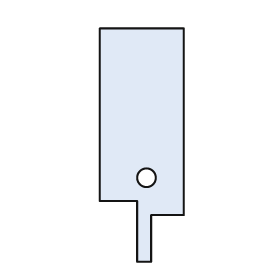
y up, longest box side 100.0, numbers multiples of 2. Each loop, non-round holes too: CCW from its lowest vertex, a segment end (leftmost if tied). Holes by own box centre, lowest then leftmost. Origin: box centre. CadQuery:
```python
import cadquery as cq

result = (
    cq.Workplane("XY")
    .moveTo(-2.0, -50.0)
    .lineTo(4.0, -50.0)
    .lineTo(4.0, -30.0)
    .lineTo(18.0, -30.0)
    .lineTo(18.0, 50.0)
    .lineTo(-18.0, 50.0)
    .lineTo(-18.0, -24.0)
    .lineTo(-2.0, -24.0)
    .close()
    .moveTo(2.0, -14.0)
    .circle(4.0)
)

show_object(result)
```